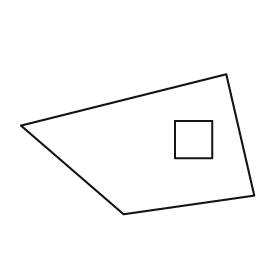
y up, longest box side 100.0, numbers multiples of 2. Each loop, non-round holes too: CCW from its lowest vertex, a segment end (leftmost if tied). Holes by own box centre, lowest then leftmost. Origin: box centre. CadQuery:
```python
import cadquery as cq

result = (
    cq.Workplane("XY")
    .moveTo(-6.0, -30.0)
    .lineTo(50.0, -22.0)
    .lineTo(38.0, 30.0)
    .lineTo(-50.0, 8.0)
    .close()
    .moveTo(16.0, -6.0)
    .lineTo(32.0, -6.0)
    .lineTo(32.0, 10.0)
    .lineTo(16.0, 10.0)
    .close()
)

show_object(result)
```